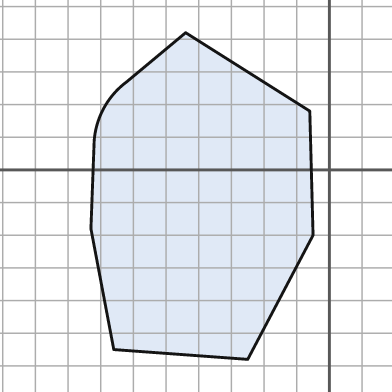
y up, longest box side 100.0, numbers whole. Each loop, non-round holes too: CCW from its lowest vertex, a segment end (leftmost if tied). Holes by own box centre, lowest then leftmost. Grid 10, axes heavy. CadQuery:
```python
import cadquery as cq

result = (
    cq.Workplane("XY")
    .moveTo(-25.0, -58.0)
    .lineTo(-5.0, -20.0)
    .lineTo(-6.0, 18.0)
    .lineTo(-44.0, 42.0)
    .lineTo(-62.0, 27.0)
    .threePointArc((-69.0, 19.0), (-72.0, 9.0))
    .lineTo(-73.0, -18.0)
    .lineTo(-66.0, -55.0)
    .close()
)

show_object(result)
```